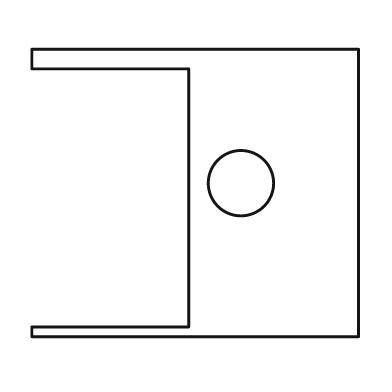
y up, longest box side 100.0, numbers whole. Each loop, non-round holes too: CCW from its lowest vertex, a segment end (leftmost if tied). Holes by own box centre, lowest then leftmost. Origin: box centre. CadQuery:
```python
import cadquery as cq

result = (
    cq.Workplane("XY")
    .moveTo(-50.0, -44.0)
    .lineTo(50.0, -44.0)
    .lineTo(50.0, 44.0)
    .lineTo(-50.0, 44.0)
    .lineTo(-50.0, 38.0)
    .lineTo(-2.0, 38.0)
    .lineTo(-2.0, -41.0)
    .lineTo(-50.0, -41.0)
    .close()
    .moveTo(14.0, 3.0)
    .circle(10.0)
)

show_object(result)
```